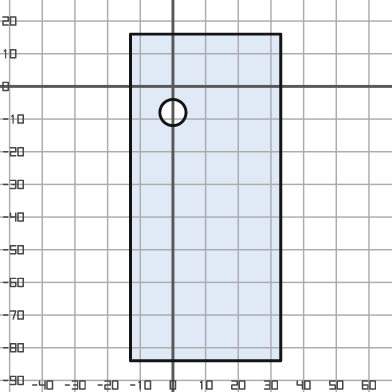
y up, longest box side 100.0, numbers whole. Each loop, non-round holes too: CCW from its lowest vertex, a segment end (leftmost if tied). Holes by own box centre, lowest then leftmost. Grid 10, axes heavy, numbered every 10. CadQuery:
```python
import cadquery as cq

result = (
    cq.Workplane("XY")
    .moveTo(-13.0, -84.0)
    .lineTo(33.0, -84.0)
    .lineTo(33.0, 16.0)
    .lineTo(-13.0, 16.0)
    .close()
    .moveTo(0.0, -8.0)
    .circle(4.0)
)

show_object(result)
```